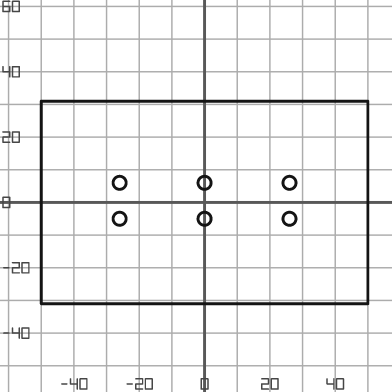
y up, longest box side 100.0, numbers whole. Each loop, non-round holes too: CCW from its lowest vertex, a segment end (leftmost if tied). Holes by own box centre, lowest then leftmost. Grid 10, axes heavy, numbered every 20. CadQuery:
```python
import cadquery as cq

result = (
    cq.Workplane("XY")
    .moveTo(-50.0, -31.0)
    .lineTo(50.0, -31.0)
    .lineTo(50.0, 31.0)
    .lineTo(-50.0, 31.0)
    .close()
    .moveTo(-26.0, -5.0)
    .circle(2.0)
    .moveTo(0.0, -5.0)
    .circle(2.0)
    .moveTo(26.0, -5.0)
    .circle(2.0)
    .moveTo(-26.0, 6.0)
    .circle(2.0)
    .moveTo(0.0, 6.0)
    .circle(2.0)
    .moveTo(26.0, 6.0)
    .circle(2.0)
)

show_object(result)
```